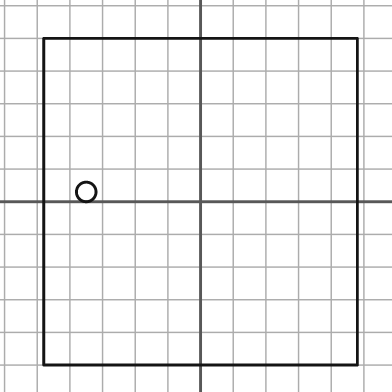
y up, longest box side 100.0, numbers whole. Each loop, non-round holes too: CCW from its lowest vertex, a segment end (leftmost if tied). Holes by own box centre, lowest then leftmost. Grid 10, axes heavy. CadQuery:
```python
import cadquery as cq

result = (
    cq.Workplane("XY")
    .moveTo(-48.0, -50.0)
    .lineTo(48.0, -50.0)
    .lineTo(48.0, 50.0)
    .lineTo(-48.0, 50.0)
    .close()
    .moveTo(-35.0, 3.0)
    .circle(3.0)
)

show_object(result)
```